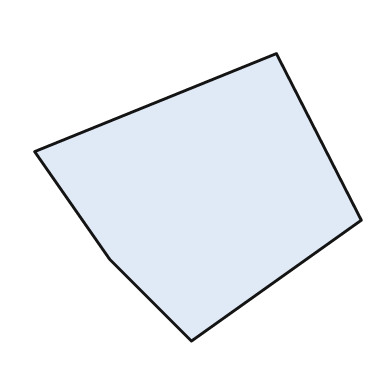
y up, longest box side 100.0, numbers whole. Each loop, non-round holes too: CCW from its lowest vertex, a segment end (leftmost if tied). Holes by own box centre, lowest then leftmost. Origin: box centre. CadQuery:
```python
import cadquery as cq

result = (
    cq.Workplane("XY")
    .moveTo(-2.0, -44.0)
    .lineTo(50.0, -7.0)
    .lineTo(24.0, 44.0)
    .lineTo(-50.0, 14.0)
    .lineTo(-27.0, -19.0)
    .close()
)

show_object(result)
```